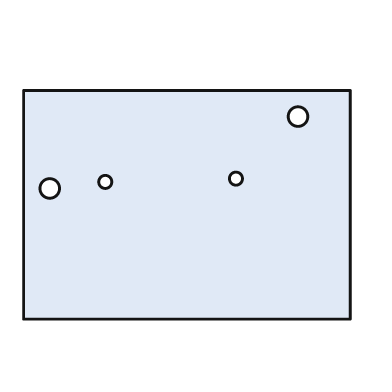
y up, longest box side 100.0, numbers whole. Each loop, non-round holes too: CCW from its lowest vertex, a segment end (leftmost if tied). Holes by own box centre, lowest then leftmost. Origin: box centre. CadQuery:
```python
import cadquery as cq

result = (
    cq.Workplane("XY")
    .moveTo(-50.0, -35.0)
    .lineTo(50.0, -35.0)
    .lineTo(50.0, 35.0)
    .lineTo(-50.0, 35.0)
    .close()
    .moveTo(-42.0, 5.0)
    .circle(3.0)
    .moveTo(-25.0, 7.0)
    .circle(2.0)
    .moveTo(15.0, 8.0)
    .circle(2.0)
    .moveTo(34.0, 27.0)
    .circle(3.0)
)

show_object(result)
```